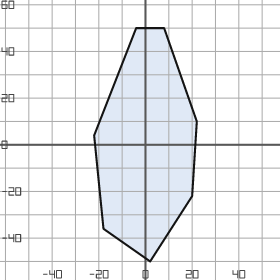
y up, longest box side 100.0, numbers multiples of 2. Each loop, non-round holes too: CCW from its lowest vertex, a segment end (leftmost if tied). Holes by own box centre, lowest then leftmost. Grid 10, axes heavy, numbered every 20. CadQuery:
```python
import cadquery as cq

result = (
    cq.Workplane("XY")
    .moveTo(2.0, -50.0)
    .lineTo(20.0, -22.0)
    .lineTo(22.0, 10.0)
    .lineTo(8.0, 50.0)
    .lineTo(-4.0, 50.0)
    .lineTo(-22.0, 4.0)
    .lineTo(-18.0, -36.0)
    .close()
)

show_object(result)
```